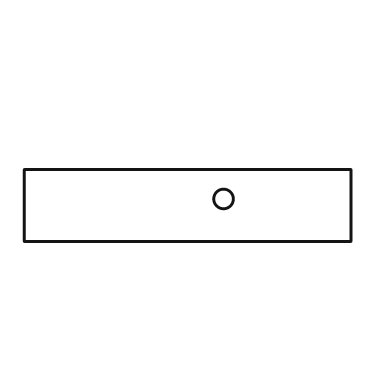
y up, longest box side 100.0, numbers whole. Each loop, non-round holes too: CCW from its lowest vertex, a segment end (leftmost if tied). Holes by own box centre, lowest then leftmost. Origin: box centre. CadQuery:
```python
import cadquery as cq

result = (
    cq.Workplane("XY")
    .moveTo(-50.0, -11.0)
    .lineTo(50.0, -11.0)
    .lineTo(50.0, 11.0)
    .lineTo(-50.0, 11.0)
    .close()
    .moveTo(11.0, 2.0)
    .circle(3.0)
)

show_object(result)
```